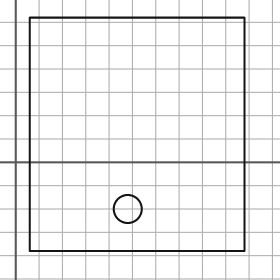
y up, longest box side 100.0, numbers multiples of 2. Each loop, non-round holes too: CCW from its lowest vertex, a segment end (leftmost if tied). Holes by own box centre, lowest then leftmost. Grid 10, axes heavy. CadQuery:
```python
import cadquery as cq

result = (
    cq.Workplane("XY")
    .moveTo(6.0, -38.0)
    .lineTo(98.0, -38.0)
    .lineTo(98.0, 62.0)
    .lineTo(6.0, 62.0)
    .close()
    .moveTo(48.0, -20.0)
    .circle(6.0)
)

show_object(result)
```